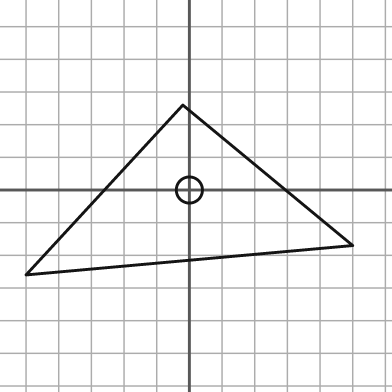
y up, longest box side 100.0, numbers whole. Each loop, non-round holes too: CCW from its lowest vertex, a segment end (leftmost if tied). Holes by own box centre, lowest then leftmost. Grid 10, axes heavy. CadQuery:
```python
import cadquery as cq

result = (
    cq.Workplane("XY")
    .moveTo(-50.0, -26.0)
    .lineTo(50.0, -17.0)
    .lineTo(-2.0, 26.0)
    .close()
    .moveTo(0.0, 0.0)
    .circle(4.0)
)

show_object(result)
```